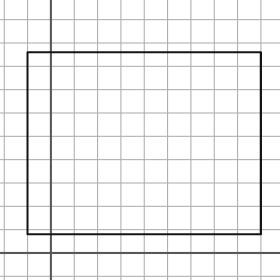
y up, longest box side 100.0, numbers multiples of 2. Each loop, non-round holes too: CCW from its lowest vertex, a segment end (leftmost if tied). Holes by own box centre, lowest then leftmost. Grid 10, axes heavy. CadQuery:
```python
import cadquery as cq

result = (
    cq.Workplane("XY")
    .moveTo(-10.0, 8.0)
    .lineTo(90.0, 8.0)
    .lineTo(90.0, 86.0)
    .lineTo(-10.0, 86.0)
    .close()
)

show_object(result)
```